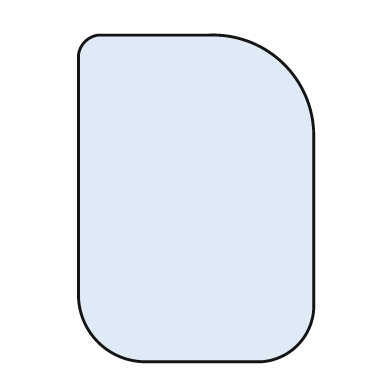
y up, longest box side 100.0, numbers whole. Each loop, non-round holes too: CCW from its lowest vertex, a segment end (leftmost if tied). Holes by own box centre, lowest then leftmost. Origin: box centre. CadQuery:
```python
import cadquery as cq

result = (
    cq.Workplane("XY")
    .moveTo(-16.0, -50.0)
    .lineTo(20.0, -50.0)
    .threePointArc((31.0, -45.0), (36.0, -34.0))
    .lineTo(36.0, 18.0)
    .threePointArc((27.0, 41.0), (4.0, 50.0))
    .lineTo(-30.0, 50.0)
    .threePointArc((-34.0, 48.0), (-36.0, 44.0))
    .lineTo(-36.0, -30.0)
    .threePointArc((-30.0, -44.0), (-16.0, -50.0))
    .close()
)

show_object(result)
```